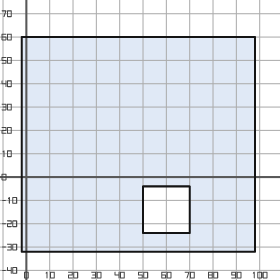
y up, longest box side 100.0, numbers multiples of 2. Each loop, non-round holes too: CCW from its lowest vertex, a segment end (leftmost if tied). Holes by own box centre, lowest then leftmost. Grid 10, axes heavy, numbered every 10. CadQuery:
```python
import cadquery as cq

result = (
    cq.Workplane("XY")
    .moveTo(-2.0, -32.0)
    .lineTo(98.0, -32.0)
    .lineTo(98.0, 60.0)
    .lineTo(-2.0, 60.0)
    .close()
    .moveTo(50.0, -24.0)
    .lineTo(70.0, -24.0)
    .lineTo(70.0, -4.0)
    .lineTo(50.0, -4.0)
    .close()
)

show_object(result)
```